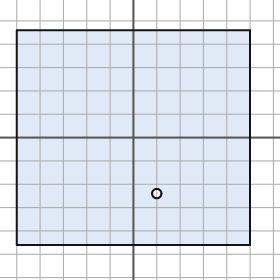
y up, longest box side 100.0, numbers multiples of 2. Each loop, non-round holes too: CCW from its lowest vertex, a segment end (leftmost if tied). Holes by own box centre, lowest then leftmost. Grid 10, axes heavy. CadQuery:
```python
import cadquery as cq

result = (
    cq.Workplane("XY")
    .moveTo(-50.0, -46.0)
    .lineTo(50.0, -46.0)
    .lineTo(50.0, 46.0)
    .lineTo(-50.0, 46.0)
    .close()
    .moveTo(10.0, -24.0)
    .circle(2.0)
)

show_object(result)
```